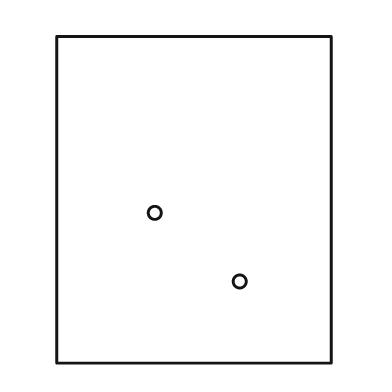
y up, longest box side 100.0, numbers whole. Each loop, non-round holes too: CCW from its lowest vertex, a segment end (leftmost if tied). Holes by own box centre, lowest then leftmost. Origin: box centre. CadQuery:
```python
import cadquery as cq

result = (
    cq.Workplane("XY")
    .moveTo(-42.0, -50.0)
    .lineTo(42.0, -50.0)
    .lineTo(42.0, 50.0)
    .lineTo(-42.0, 50.0)
    .close()
    .moveTo(14.0, -25.0)
    .circle(2.0)
    .moveTo(-12.0, -4.0)
    .circle(2.0)
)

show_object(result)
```